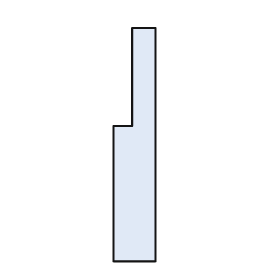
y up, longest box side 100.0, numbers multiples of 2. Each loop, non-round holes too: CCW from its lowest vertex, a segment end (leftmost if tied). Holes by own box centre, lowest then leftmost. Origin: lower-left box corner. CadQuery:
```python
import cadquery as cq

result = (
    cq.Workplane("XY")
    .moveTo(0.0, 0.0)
    .lineTo(18.0, 0.0)
    .lineTo(18.0, 100.0)
    .lineTo(8.0, 100.0)
    .lineTo(8.0, 58.0)
    .lineTo(0.0, 58.0)
    .close()
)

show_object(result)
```